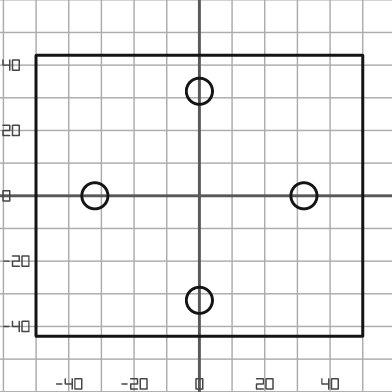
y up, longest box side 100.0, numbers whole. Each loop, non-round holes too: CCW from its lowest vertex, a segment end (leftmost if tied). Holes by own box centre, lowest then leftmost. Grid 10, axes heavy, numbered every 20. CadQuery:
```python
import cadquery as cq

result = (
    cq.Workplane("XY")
    .moveTo(-50.0, -43.0)
    .lineTo(50.0, -43.0)
    .lineTo(50.0, 43.0)
    .lineTo(-50.0, 43.0)
    .close()
    .moveTo(0.0, -32.0)
    .circle(4.0)
    .moveTo(-32.0, 0.0)
    .circle(4.0)
    .moveTo(32.0, 0.0)
    .circle(4.0)
    .moveTo(0.0, 32.0)
    .circle(4.0)
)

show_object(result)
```